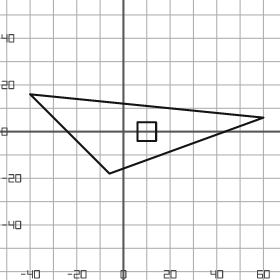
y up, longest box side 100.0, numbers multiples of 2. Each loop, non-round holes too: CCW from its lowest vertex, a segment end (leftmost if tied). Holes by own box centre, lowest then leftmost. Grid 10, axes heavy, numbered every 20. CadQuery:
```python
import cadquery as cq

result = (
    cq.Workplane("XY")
    .moveTo(-6.0, -18.0)
    .lineTo(60.0, 6.0)
    .lineTo(-40.0, 16.0)
    .close()
    .moveTo(6.0, -4.0)
    .lineTo(14.0, -4.0)
    .lineTo(14.0, 4.0)
    .lineTo(6.0, 4.0)
    .close()
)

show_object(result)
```